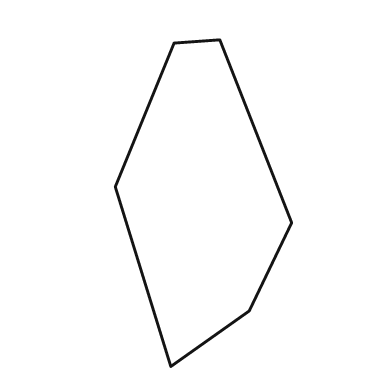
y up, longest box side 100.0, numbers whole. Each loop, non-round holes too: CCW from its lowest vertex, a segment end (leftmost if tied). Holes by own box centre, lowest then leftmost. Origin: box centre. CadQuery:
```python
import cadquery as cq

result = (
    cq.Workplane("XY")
    .moveTo(-10.0, -50.0)
    .lineTo(14.0, -33.0)
    .lineTo(27.0, -6.0)
    .lineTo(5.0, 50.0)
    .lineTo(-9.0, 49.0)
    .lineTo(-27.0, 5.0)
    .close()
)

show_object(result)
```